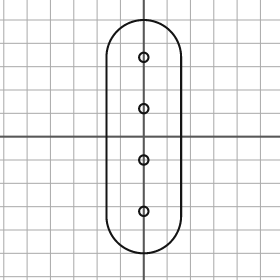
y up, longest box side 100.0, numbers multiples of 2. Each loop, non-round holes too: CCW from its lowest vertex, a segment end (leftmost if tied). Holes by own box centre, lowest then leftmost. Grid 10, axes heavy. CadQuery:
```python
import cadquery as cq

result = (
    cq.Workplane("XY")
    .moveTo(-16.0, -34.0)
    .threePointArc((0.0, -50.0), (16.0, -34.0))
    .lineTo(16.0, 34.0)
    .threePointArc((0.0, 50.0), (-16.0, 34.0))
    .close()
    .moveTo(0.0, -32.0)
    .circle(2.0)
    .moveTo(0.0, -10.0)
    .circle(2.0)
    .moveTo(0.0, 12.0)
    .circle(2.0)
    .moveTo(0.0, 34.0)
    .circle(2.0)
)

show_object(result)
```